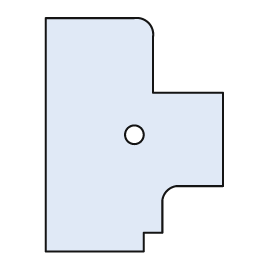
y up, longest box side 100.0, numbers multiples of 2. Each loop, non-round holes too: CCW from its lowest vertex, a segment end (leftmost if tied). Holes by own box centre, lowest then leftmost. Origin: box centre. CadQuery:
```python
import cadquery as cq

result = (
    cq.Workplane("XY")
    .moveTo(-38.0, -50.0)
    .lineTo(4.0, -50.0)
    .lineTo(4.0, -42.0)
    .lineTo(12.0, -42.0)
    .lineTo(12.0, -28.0)
    .threePointArc((14.0, -24.0), (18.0, -22.0))
    .lineTo(38.0, -22.0)
    .lineTo(38.0, 18.0)
    .lineTo(8.0, 18.0)
    .lineTo(8.0, 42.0)
    .threePointArc((6.0, 48.0), (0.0, 50.0))
    .lineTo(-38.0, 50.0)
    .close()
    .moveTo(0.0, 0.0)
    .circle(4.0)
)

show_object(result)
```